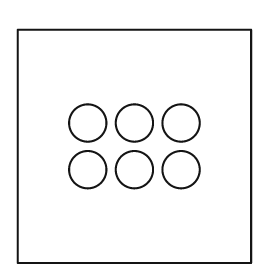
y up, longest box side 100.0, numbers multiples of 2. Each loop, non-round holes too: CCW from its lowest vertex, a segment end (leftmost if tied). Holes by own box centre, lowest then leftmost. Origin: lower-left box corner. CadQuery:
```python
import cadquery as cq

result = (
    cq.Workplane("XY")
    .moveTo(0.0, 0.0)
    .lineTo(100.0, 0.0)
    .lineTo(100.0, 100.0)
    .lineTo(0.0, 100.0)
    .close()
    .moveTo(30.0, 40.0)
    .circle(8.0)
    .moveTo(50.0, 40.0)
    .circle(8.0)
    .moveTo(70.0, 40.0)
    .circle(8.0)
    .moveTo(30.0, 60.0)
    .circle(8.0)
    .moveTo(50.0, 60.0)
    .circle(8.0)
    .moveTo(70.0, 60.0)
    .circle(8.0)
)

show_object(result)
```